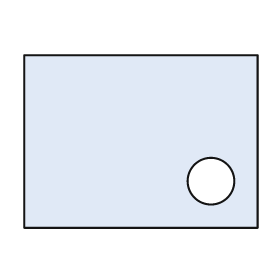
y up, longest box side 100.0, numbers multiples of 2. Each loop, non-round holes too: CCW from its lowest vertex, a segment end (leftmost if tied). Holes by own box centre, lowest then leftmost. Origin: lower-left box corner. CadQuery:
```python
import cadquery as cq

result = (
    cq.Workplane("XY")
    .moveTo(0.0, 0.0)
    .lineTo(100.0, 0.0)
    .lineTo(100.0, 74.0)
    .lineTo(0.0, 74.0)
    .close()
    .moveTo(80.0, 20.0)
    .circle(10.0)
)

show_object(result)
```